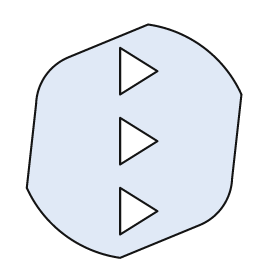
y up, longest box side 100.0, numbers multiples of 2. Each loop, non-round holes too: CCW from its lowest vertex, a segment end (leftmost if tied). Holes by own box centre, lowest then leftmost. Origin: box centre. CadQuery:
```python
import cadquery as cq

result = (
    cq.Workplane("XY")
    .moveTo(-6.0, -50.0)
    .lineTo(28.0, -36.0)
    .threePointArc((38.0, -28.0), (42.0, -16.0))
    .lineTo(46.0, 20.0)
    .threePointArc((30.0, 40.0), (6.0, 50.0))
    .lineTo(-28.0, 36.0)
    .threePointArc((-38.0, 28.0), (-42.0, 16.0))
    .lineTo(-46.0, -20.0)
    .threePointArc((-30.0, -40.0), (-6.0, -50.0))
    .close()
    .moveTo(-6.0, -40.0)
    .lineTo(10.0, -30.0)
    .lineTo(-6.0, -20.0)
    .close()
    .moveTo(-6.0, -10.0)
    .lineTo(10.0, 0.0)
    .lineTo(-6.0, 10.0)
    .close()
    .moveTo(-6.0, 20.0)
    .lineTo(10.0, 30.0)
    .lineTo(-6.0, 40.0)
    .close()
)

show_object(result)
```